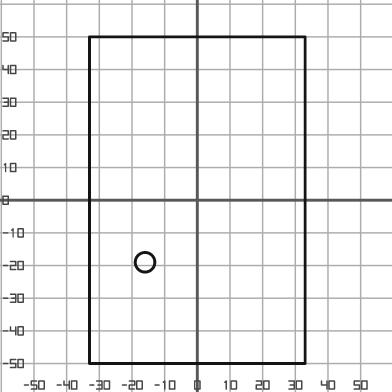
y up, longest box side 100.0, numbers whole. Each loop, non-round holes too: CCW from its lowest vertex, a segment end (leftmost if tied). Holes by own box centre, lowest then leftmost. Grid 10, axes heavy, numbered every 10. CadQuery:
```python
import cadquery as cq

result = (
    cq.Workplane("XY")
    .moveTo(-33.0, -50.0)
    .lineTo(33.0, -50.0)
    .lineTo(33.0, 50.0)
    .lineTo(-33.0, 50.0)
    .close()
    .moveTo(-16.0, -19.0)
    .circle(3.0)
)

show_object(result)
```